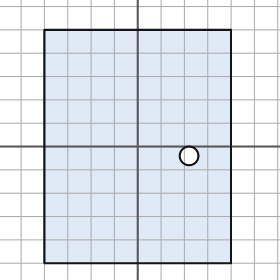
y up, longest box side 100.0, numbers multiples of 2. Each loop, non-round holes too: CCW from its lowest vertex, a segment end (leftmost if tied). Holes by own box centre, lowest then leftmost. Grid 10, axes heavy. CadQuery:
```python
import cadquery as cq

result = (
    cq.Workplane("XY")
    .moveTo(-40.0, -50.0)
    .lineTo(40.0, -50.0)
    .lineTo(40.0, 50.0)
    .lineTo(-40.0, 50.0)
    .close()
    .moveTo(22.0, -4.0)
    .circle(4.0)
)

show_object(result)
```